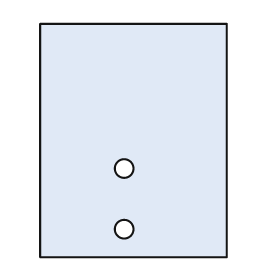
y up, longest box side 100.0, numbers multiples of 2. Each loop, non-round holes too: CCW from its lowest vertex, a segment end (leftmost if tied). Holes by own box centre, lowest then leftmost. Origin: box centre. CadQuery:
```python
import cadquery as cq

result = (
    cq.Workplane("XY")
    .moveTo(-40.0, -50.0)
    .lineTo(40.0, -50.0)
    .lineTo(40.0, 50.0)
    .lineTo(-40.0, 50.0)
    .close()
    .moveTo(-4.0, -38.0)
    .circle(4.0)
    .moveTo(-4.0, -12.0)
    .circle(4.0)
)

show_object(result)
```